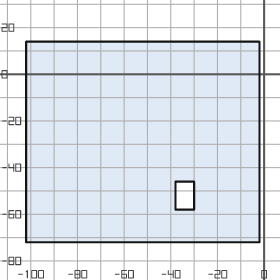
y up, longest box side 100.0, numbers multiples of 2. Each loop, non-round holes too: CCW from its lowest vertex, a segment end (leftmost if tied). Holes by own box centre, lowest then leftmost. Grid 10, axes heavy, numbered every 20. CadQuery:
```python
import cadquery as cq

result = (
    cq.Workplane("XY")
    .moveTo(-102.0, -72.0)
    .lineTo(-2.0, -72.0)
    .lineTo(-2.0, 14.0)
    .lineTo(-102.0, 14.0)
    .close()
    .moveTo(-38.0, -58.0)
    .lineTo(-30.0, -58.0)
    .lineTo(-30.0, -46.0)
    .lineTo(-38.0, -46.0)
    .close()
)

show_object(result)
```